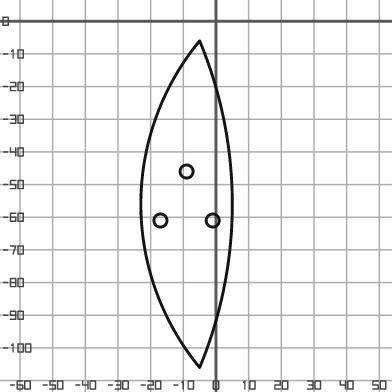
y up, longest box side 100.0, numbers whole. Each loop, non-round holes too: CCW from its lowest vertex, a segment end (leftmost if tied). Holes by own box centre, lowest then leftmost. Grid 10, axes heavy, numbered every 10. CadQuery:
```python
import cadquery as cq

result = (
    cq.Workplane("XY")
    .moveTo(-5.0, -106.0)
    .threePointArc((5.0, -56.0), (-5.0, -6.0))
    .threePointArc((-23.0, -56.0), (-5.0, -106.0))
    .close()
    .moveTo(-17.0, -61.0)
    .circle(2.0)
    .moveTo(-1.0, -61.0)
    .circle(2.0)
    .moveTo(-9.0, -46.0)
    .circle(2.0)
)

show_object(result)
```